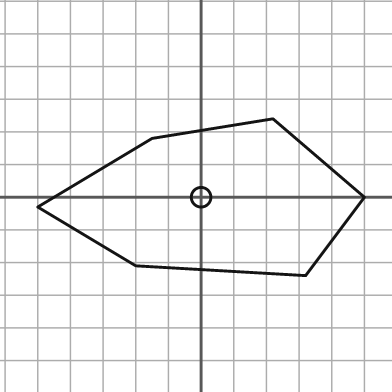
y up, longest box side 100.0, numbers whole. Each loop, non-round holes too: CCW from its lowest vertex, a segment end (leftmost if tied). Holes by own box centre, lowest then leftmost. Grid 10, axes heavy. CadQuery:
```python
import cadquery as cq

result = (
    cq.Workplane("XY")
    .moveTo(32.0, -24.0)
    .lineTo(50.0, 0.0)
    .lineTo(22.0, 24.0)
    .lineTo(-15.0, 18.0)
    .lineTo(-50.0, -3.0)
    .lineTo(-20.0, -21.0)
    .close()
    .moveTo(0.0, 0.0)
    .circle(3.0)
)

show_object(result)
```